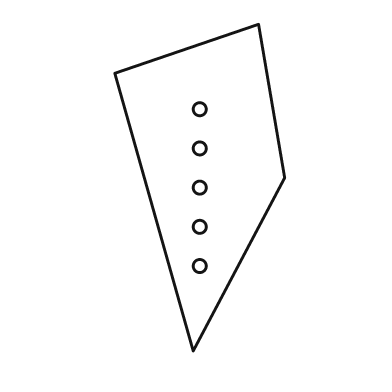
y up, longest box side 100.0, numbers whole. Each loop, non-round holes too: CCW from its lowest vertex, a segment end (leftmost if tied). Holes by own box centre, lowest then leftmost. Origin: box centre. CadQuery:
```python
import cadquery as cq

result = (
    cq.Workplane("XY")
    .moveTo(-2.0, -50.0)
    .lineTo(26.0, 3.0)
    .lineTo(18.0, 50.0)
    .lineTo(-26.0, 35.0)
    .close()
    .moveTo(0.0, -24.0)
    .circle(2.0)
    .moveTo(0.0, -12.0)
    .circle(2.0)
    .moveTo(0.0, 0.0)
    .circle(2.0)
    .moveTo(0.0, 12.0)
    .circle(2.0)
    .moveTo(0.0, 24.0)
    .circle(2.0)
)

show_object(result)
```